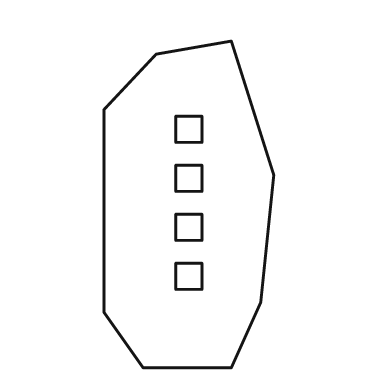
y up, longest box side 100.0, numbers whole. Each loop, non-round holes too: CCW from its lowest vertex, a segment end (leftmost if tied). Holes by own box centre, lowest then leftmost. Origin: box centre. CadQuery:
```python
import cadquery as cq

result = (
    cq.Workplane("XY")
    .moveTo(-14.0, -50.0)
    .lineTo(13.0, -50.0)
    .lineTo(22.0, -30.0)
    .lineTo(26.0, 9.0)
    .lineTo(13.0, 50.0)
    .lineTo(-10.0, 46.0)
    .lineTo(-26.0, 29.0)
    .lineTo(-26.0, -33.0)
    .close()
    .moveTo(-4.0, -26.0)
    .lineTo(4.0, -26.0)
    .lineTo(4.0, -18.0)
    .lineTo(-4.0, -18.0)
    .close()
    .moveTo(-4.0, -11.0)
    .lineTo(4.0, -11.0)
    .lineTo(4.0, -3.0)
    .lineTo(-4.0, -3.0)
    .close()
    .moveTo(-4.0, 4.0)
    .lineTo(4.0, 4.0)
    .lineTo(4.0, 12.0)
    .lineTo(-4.0, 12.0)
    .close()
    .moveTo(-4.0, 19.0)
    .lineTo(4.0, 19.0)
    .lineTo(4.0, 27.0)
    .lineTo(-4.0, 27.0)
    .close()
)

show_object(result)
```